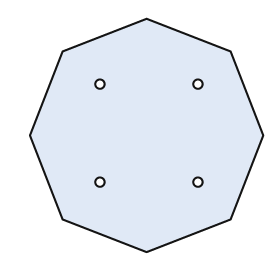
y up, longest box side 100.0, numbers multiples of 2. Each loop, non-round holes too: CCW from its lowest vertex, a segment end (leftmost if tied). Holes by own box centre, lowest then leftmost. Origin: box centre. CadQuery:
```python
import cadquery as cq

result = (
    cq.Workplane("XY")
    .moveTo(0.0, -50.0)
    .lineTo(36.0, -36.0)
    .lineTo(50.0, 0.0)
    .lineTo(36.0, 36.0)
    .lineTo(0.0, 50.0)
    .lineTo(-36.0, 36.0)
    .lineTo(-50.0, 0.0)
    .lineTo(-36.0, -36.0)
    .close()
    .moveTo(-20.0, -20.0)
    .circle(2.0)
    .moveTo(22.0, -20.0)
    .circle(2.0)
    .moveTo(-20.0, 22.0)
    .circle(2.0)
    .moveTo(22.0, 22.0)
    .circle(2.0)
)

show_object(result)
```